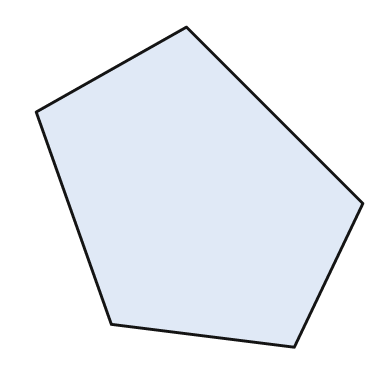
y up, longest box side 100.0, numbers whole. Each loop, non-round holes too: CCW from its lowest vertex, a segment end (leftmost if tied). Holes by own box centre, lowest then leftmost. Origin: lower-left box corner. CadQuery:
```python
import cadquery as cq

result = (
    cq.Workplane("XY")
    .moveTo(79.0, 0.0)
    .lineTo(100.0, 44.0)
    .lineTo(46.0, 98.0)
    .lineTo(0.0, 72.0)
    .lineTo(23.0, 7.0)
    .close()
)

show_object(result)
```